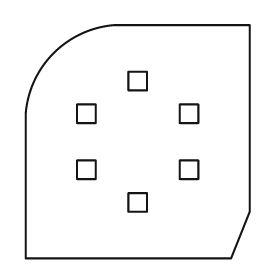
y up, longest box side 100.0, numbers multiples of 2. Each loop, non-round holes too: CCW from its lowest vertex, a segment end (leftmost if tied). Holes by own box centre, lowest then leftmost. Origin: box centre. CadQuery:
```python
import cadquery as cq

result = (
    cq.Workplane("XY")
    .moveTo(-48.0, -50.0)
    .lineTo(40.0, -50.0)
    .lineTo(48.0, -30.0)
    .lineTo(48.0, 50.0)
    .lineTo(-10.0, 50.0)
    .threePointArc((-36.0, 38.0), (-48.0, 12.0))
    .close()
    .moveTo(-4.0, -30.0)
    .lineTo(4.0, -30.0)
    .lineTo(4.0, -22.0)
    .lineTo(-4.0, -22.0)
    .close()
    .moveTo(-26.0, -16.0)
    .lineTo(-18.0, -16.0)
    .lineTo(-18.0, -8.0)
    .lineTo(-26.0, -8.0)
    .close()
    .moveTo(18.0, -16.0)
    .lineTo(26.0, -16.0)
    .lineTo(26.0, -8.0)
    .lineTo(18.0, -8.0)
    .close()
    .moveTo(-26.0, 8.0)
    .lineTo(-18.0, 8.0)
    .lineTo(-18.0, 16.0)
    .lineTo(-26.0, 16.0)
    .close()
    .moveTo(18.0, 8.0)
    .lineTo(26.0, 8.0)
    .lineTo(26.0, 16.0)
    .lineTo(18.0, 16.0)
    .close()
    .moveTo(-4.0, 22.0)
    .lineTo(4.0, 22.0)
    .lineTo(4.0, 30.0)
    .lineTo(-4.0, 30.0)
    .close()
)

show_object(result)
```